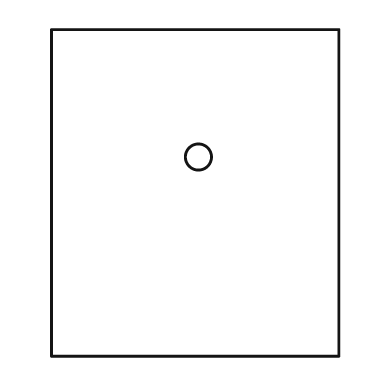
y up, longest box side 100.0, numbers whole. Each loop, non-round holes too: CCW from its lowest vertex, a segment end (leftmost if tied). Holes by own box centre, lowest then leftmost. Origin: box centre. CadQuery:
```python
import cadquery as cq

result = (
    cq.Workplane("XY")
    .moveTo(-44.0, -50.0)
    .lineTo(44.0, -50.0)
    .lineTo(44.0, 50.0)
    .lineTo(-44.0, 50.0)
    .close()
    .moveTo(1.0, 11.0)
    .circle(4.0)
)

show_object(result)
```